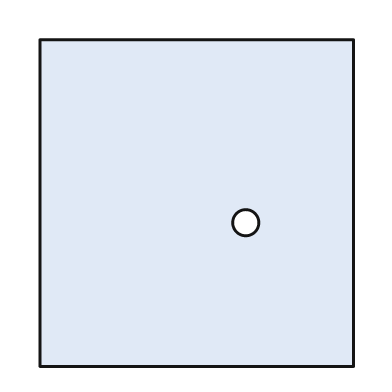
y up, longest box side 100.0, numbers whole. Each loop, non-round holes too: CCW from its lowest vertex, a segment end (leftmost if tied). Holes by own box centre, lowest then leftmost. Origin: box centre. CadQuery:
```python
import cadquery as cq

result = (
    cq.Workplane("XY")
    .moveTo(-48.0, -50.0)
    .lineTo(48.0, -50.0)
    .lineTo(48.0, 50.0)
    .lineTo(-48.0, 50.0)
    .close()
    .moveTo(15.0, -6.0)
    .circle(4.0)
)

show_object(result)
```